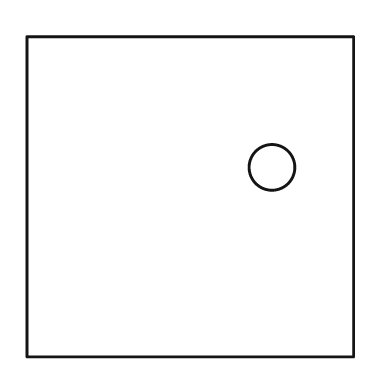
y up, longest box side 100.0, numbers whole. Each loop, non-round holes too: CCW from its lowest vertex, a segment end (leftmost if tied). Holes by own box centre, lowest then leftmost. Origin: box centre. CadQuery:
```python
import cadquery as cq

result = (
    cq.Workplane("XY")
    .moveTo(-50.0, -49.0)
    .lineTo(50.0, -49.0)
    .lineTo(50.0, 49.0)
    .lineTo(-50.0, 49.0)
    .close()
    .moveTo(25.0, 9.0)
    .circle(7.0)
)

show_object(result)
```